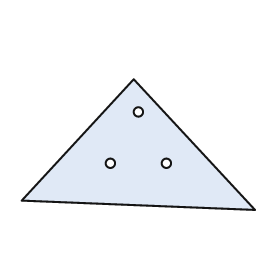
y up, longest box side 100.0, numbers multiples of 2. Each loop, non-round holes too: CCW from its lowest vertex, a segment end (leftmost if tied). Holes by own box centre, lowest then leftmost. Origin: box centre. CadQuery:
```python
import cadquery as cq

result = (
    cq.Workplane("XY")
    .moveTo(50.0, -28.0)
    .lineTo(-2.0, 28.0)
    .lineTo(-50.0, -24.0)
    .close()
    .moveTo(-12.0, -8.0)
    .circle(2.0)
    .moveTo(12.0, -8.0)
    .circle(2.0)
    .moveTo(0.0, 14.0)
    .circle(2.0)
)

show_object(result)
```